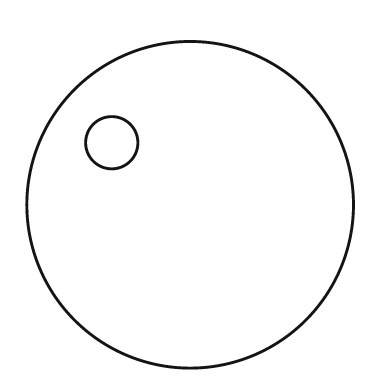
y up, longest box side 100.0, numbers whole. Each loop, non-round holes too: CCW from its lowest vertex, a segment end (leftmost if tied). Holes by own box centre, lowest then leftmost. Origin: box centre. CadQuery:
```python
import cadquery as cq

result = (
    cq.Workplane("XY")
    .moveTo(0.0, 0.0)
    .circle(50.0)
    .moveTo(-24.0, 19.0)
    .circle(8.0)
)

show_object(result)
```